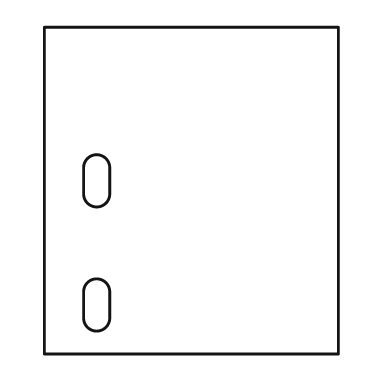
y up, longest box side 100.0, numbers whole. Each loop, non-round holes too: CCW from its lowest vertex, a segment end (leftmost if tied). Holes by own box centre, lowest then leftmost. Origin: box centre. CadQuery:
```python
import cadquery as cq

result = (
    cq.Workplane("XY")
    .moveTo(-45.0, -50.0)
    .lineTo(45.0, -50.0)
    .lineTo(45.0, 50.0)
    .lineTo(-45.0, 50.0)
    .close()
    .moveTo(-33.0, -39.0)
    .threePointArc((-29.0, -43.0), (-25.0, -39.0))
    .lineTo(-25.0, -31.0)
    .threePointArc((-29.0, -27.0), (-33.0, -31.0))
    .close()
    .moveTo(-33.0, -1.0)
    .threePointArc((-29.0, -5.0), (-25.0, -1.0))
    .lineTo(-25.0, 7.0)
    .threePointArc((-29.0, 11.0), (-33.0, 7.0))
    .close()
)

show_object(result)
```